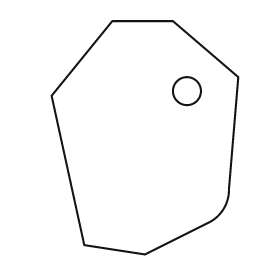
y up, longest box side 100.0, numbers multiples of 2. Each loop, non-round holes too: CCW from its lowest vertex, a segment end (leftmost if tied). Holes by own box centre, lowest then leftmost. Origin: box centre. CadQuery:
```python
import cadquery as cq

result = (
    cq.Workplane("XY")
    .moveTo(0.0, -50.0)
    .lineTo(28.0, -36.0)
    .threePointArc((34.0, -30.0), (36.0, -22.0))
    .lineTo(40.0, 26.0)
    .lineTo(12.0, 50.0)
    .lineTo(-14.0, 50.0)
    .lineTo(-40.0, 18.0)
    .lineTo(-26.0, -46.0)
    .close()
    .moveTo(18.0, 20.0)
    .circle(6.0)
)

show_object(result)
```